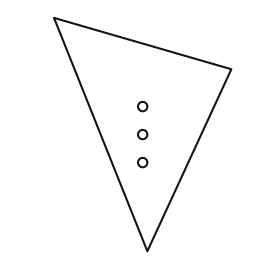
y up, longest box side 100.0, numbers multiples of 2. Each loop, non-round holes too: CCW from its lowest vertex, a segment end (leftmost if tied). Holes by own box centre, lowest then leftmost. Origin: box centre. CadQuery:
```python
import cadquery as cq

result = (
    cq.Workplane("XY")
    .moveTo(2.0, -50.0)
    .lineTo(38.0, 28.0)
    .lineTo(-38.0, 50.0)
    .close()
    .moveTo(0.0, -12.0)
    .circle(2.0)
    .moveTo(0.0, 0.0)
    .circle(2.0)
    .moveTo(0.0, 12.0)
    .circle(2.0)
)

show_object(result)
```